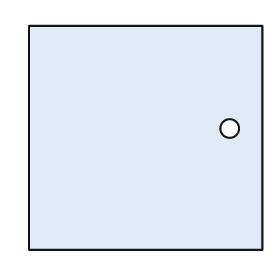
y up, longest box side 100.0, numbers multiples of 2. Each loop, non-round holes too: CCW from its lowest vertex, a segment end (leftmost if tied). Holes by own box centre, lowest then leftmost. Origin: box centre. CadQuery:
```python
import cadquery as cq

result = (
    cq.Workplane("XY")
    .moveTo(-50.0, -48.0)
    .lineTo(50.0, -48.0)
    .lineTo(50.0, 48.0)
    .lineTo(-50.0, 48.0)
    .close()
    .moveTo(36.0, 4.0)
    .circle(4.0)
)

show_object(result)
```